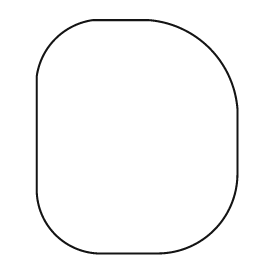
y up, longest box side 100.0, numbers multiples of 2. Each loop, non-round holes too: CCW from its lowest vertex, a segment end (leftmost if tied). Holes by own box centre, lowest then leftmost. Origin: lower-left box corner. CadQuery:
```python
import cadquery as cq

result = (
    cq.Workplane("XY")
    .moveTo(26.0, 0.0)
    .lineTo(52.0, 0.0)
    .threePointArc((76.0, 10.0), (86.0, 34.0))
    .lineTo(86.0, 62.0)
    .threePointArc((74.0, 88.0), (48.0, 100.0))
    .lineTo(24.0, 100.0)
    .threePointArc((8.0, 92.0), (0.0, 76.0))
    .lineTo(0.0, 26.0)
    .threePointArc((8.0, 8.0), (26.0, 0.0))
    .close()
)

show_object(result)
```